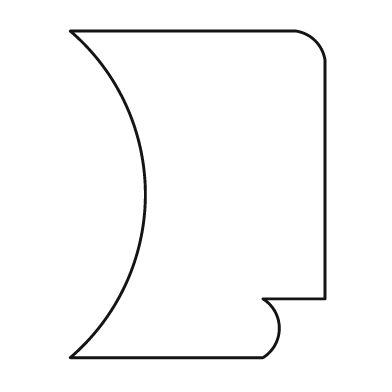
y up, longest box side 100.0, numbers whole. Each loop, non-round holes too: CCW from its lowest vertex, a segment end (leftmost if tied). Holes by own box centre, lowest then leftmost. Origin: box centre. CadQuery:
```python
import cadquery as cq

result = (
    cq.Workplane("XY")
    .moveTo(-39.0, -50.0)
    .lineTo(20.0, -50.0)
    .threePointArc((25.0, -41.0), (20.0, -32.0))
    .lineTo(39.0, -32.0)
    .lineTo(39.0, 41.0)
    .threePointArc((36.0, 47.0), (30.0, 50.0))
    .lineTo(-39.0, 50.0)
    .threePointArc((-16.0, 0.0), (-39.0, -50.0))
    .close()
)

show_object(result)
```